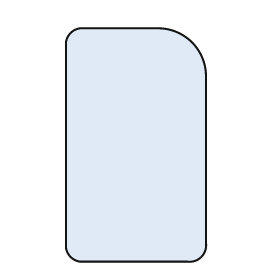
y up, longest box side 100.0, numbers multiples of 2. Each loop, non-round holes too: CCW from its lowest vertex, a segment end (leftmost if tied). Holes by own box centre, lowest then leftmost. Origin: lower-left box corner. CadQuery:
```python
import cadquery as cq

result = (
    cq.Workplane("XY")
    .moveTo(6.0, 0.0)
    .lineTo(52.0, 0.0)
    .threePointArc((58.0, 2.0), (60.0, 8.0))
    .lineTo(60.0, 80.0)
    .threePointArc((54.0, 94.0), (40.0, 100.0))
    .lineTo(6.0, 100.0)
    .threePointArc((2.0, 98.0), (0.0, 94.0))
    .lineTo(0.0, 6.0)
    .threePointArc((2.0, 2.0), (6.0, 0.0))
    .close()
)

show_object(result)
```